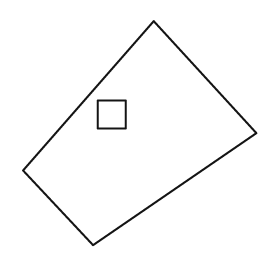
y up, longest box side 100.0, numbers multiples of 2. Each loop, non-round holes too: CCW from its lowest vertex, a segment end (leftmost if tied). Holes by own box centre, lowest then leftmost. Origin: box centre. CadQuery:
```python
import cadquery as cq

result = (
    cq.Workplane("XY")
    .moveTo(-20.0, -48.0)
    .lineTo(50.0, 0.0)
    .lineTo(6.0, 48.0)
    .lineTo(-50.0, -16.0)
    .close()
    .moveTo(-18.0, 2.0)
    .lineTo(-6.0, 2.0)
    .lineTo(-6.0, 14.0)
    .lineTo(-18.0, 14.0)
    .close()
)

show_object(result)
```